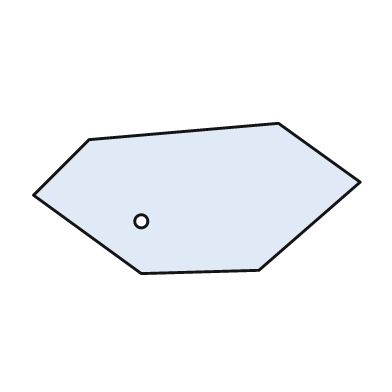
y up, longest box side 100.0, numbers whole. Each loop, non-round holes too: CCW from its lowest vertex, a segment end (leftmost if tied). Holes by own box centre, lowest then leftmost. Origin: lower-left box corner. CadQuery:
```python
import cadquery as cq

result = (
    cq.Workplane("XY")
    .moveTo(33.0, 0.0)
    .lineTo(69.0, 1.0)
    .lineTo(100.0, 28.0)
    .lineTo(75.0, 46.0)
    .lineTo(17.0, 41.0)
    .lineTo(0.0, 24.0)
    .close()
    .moveTo(33.0, 16.0)
    .circle(2.0)
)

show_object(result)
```